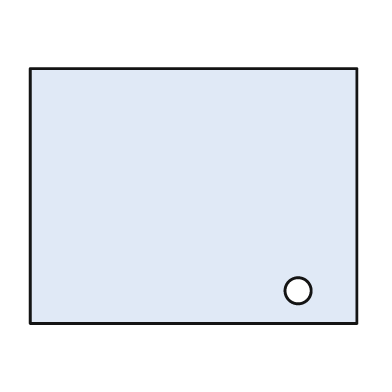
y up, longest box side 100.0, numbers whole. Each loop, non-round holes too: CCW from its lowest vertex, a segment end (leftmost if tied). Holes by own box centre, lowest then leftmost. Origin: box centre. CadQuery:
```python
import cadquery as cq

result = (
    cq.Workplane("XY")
    .moveTo(-50.0, -39.0)
    .lineTo(50.0, -39.0)
    .lineTo(50.0, 39.0)
    .lineTo(-50.0, 39.0)
    .close()
    .moveTo(32.0, -29.0)
    .circle(4.0)
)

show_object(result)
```